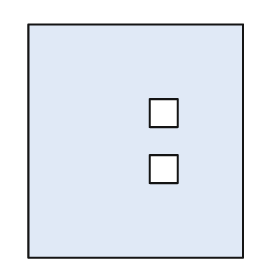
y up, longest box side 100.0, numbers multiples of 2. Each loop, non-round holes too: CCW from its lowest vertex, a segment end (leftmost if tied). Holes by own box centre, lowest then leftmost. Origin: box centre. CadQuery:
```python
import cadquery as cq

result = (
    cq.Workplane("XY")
    .moveTo(-46.0, -50.0)
    .lineTo(46.0, -50.0)
    .lineTo(46.0, 50.0)
    .lineTo(-46.0, 50.0)
    .close()
    .moveTo(6.0, -18.0)
    .lineTo(18.0, -18.0)
    .lineTo(18.0, -6.0)
    .lineTo(6.0, -6.0)
    .close()
    .moveTo(6.0, 6.0)
    .lineTo(18.0, 6.0)
    .lineTo(18.0, 18.0)
    .lineTo(6.0, 18.0)
    .close()
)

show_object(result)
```